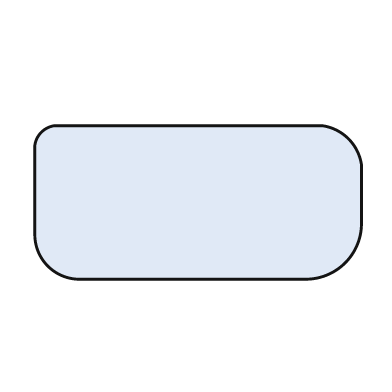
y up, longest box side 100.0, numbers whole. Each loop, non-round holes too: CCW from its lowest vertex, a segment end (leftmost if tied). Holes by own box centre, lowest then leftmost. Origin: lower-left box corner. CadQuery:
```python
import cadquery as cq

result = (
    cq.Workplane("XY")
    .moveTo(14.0, 0.0)
    .lineTo(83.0, 0.0)
    .threePointArc((95.0, 5.0), (100.0, 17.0))
    .lineTo(100.0, 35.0)
    .threePointArc((96.0, 43.0), (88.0, 47.0))
    .lineTo(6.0, 47.0)
    .threePointArc((2.0, 45.0), (0.0, 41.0))
    .lineTo(0.0, 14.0)
    .threePointArc((4.0, 4.0), (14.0, 0.0))
    .close()
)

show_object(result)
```